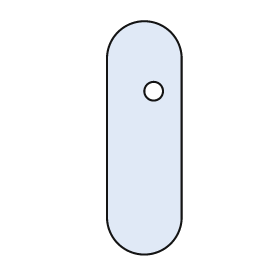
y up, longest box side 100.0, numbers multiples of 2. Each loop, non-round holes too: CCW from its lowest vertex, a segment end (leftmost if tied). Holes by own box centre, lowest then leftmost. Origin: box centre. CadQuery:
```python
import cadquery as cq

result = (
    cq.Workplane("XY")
    .moveTo(-16.0, -34.0)
    .threePointArc((0.0, -50.0), (16.0, -34.0))
    .lineTo(16.0, 34.0)
    .threePointArc((0.0, 50.0), (-16.0, 34.0))
    .close()
    .moveTo(4.0, 20.0)
    .circle(4.0)
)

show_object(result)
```